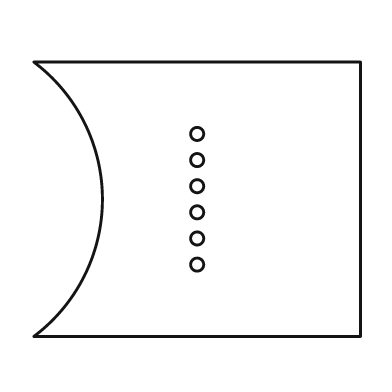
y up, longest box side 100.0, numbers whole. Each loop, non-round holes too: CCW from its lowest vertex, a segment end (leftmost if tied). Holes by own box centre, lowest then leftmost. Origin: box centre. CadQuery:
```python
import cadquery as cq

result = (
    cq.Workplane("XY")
    .moveTo(-50.0, -42.0)
    .lineTo(50.0, -42.0)
    .lineTo(50.0, 42.0)
    .lineTo(-50.0, 42.0)
    .threePointArc((-29.0, 0.0), (-50.0, -42.0))
    .close()
    .moveTo(0.0, -20.0)
    .circle(2.0)
    .moveTo(0.0, -12.0)
    .circle(2.0)
    .moveTo(0.0, -4.0)
    .circle(2.0)
    .moveTo(0.0, 4.0)
    .circle(2.0)
    .moveTo(0.0, 12.0)
    .circle(2.0)
    .moveTo(0.0, 20.0)
    .circle(2.0)
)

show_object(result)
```